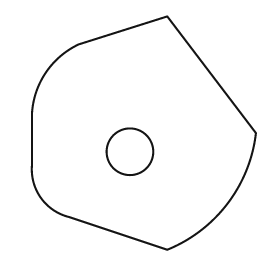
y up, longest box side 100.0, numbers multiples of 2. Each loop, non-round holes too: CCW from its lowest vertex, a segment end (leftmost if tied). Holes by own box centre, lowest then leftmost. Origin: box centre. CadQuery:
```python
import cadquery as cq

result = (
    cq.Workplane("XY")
    .moveTo(10.0, -50.0)
    .threePointArc((36.0, -30.0), (48.0, 0.0))
    .lineTo(10.0, 50.0)
    .lineTo(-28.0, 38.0)
    .threePointArc((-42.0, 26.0), (-48.0, 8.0))
    .lineTo(-48.0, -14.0)
    .threePointArc((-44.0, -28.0), (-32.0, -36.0))
    .close()
    .moveTo(-6.0, -8.0)
    .circle(10.0)
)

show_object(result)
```